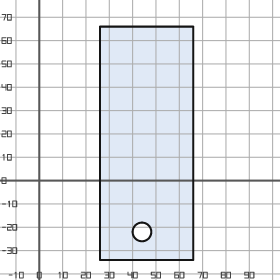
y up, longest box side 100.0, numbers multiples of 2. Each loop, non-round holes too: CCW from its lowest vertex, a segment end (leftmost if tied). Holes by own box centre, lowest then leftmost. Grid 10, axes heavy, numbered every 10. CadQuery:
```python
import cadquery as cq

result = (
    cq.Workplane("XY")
    .moveTo(26.0, -34.0)
    .lineTo(66.0, -34.0)
    .lineTo(66.0, 66.0)
    .lineTo(26.0, 66.0)
    .close()
    .moveTo(44.0, -22.0)
    .circle(4.0)
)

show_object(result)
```